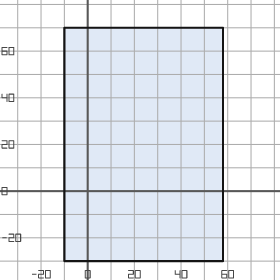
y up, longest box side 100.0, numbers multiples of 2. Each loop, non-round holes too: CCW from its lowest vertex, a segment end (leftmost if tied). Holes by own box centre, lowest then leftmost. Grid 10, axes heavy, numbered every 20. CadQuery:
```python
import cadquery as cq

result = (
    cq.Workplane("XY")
    .moveTo(-10.0, -30.0)
    .lineTo(58.0, -30.0)
    .lineTo(58.0, 70.0)
    .lineTo(-10.0, 70.0)
    .close()
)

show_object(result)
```